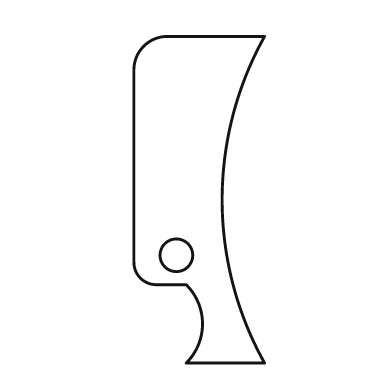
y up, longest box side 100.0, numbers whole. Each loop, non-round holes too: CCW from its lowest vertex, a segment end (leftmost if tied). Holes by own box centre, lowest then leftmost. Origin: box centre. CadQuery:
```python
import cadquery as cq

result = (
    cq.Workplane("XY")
    .moveTo(-4.0, -50.0)
    .lineTo(20.0, -50.0)
    .threePointArc((7.0, 0.0), (20.0, 50.0))
    .lineTo(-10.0, 50.0)
    .threePointArc((-17.0, 47.0), (-20.0, 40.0))
    .lineTo(-20.0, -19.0)
    .threePointArc((-18.0, -24.0), (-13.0, -26.0))
    .lineTo(-4.0, -26.0)
    .threePointArc((1.0, -38.0), (-4.0, -50.0))
    .close()
    .moveTo(-7.0, -17.0)
    .circle(5.0)
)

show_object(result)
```